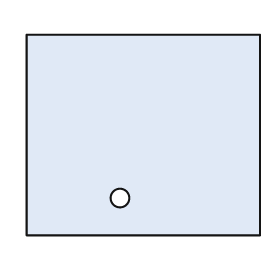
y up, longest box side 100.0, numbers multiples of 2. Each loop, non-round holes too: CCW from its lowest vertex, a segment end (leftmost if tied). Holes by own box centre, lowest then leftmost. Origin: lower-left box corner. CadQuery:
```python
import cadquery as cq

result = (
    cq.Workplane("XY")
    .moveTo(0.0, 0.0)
    .lineTo(100.0, 0.0)
    .lineTo(100.0, 86.0)
    .lineTo(0.0, 86.0)
    .close()
    .moveTo(40.0, 16.0)
    .circle(4.0)
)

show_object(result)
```